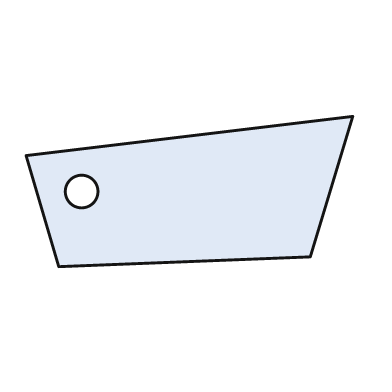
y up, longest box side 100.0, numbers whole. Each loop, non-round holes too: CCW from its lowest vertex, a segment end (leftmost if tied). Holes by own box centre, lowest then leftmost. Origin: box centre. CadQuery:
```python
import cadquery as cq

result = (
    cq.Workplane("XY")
    .moveTo(-40.0, -23.0)
    .lineTo(37.0, -20.0)
    .lineTo(50.0, 23.0)
    .lineTo(-50.0, 11.0)
    .close()
    .moveTo(-33.0, 0.0)
    .circle(5.0)
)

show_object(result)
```